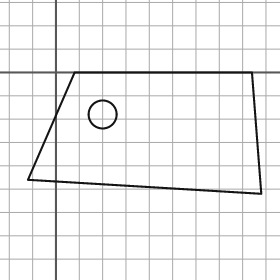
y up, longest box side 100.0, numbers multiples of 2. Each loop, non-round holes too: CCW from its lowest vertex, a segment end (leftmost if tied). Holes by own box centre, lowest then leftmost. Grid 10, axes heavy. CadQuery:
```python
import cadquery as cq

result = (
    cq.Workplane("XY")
    .moveTo(88.0, -52.0)
    .lineTo(84.0, 0.0)
    .lineTo(8.0, 0.0)
    .lineTo(-12.0, -46.0)
    .close()
    .moveTo(20.0, -18.0)
    .circle(6.0)
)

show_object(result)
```